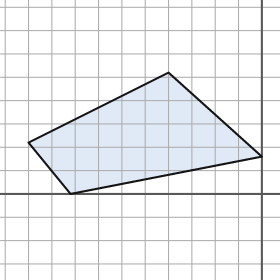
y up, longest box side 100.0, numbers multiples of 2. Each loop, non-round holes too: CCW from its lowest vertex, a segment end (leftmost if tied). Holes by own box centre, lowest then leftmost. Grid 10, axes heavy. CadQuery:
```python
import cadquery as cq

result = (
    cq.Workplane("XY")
    .moveTo(-82.0, 0.0)
    .lineTo(0.0, 16.0)
    .lineTo(-40.0, 52.0)
    .lineTo(-100.0, 22.0)
    .close()
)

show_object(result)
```